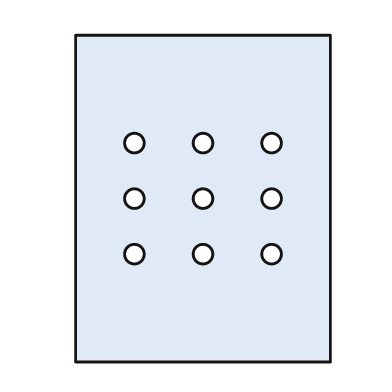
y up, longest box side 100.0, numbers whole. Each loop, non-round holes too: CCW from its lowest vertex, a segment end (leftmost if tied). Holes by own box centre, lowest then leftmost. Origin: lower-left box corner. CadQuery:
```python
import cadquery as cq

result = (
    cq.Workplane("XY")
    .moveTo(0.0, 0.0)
    .lineTo(78.0, 0.0)
    .lineTo(78.0, 100.0)
    .lineTo(0.0, 100.0)
    .close()
    .moveTo(18.0, 33.0)
    .circle(3.0)
    .moveTo(39.0, 33.0)
    .circle(3.0)
    .moveTo(60.0, 33.0)
    .circle(3.0)
    .moveTo(18.0, 50.0)
    .circle(3.0)
    .moveTo(39.0, 50.0)
    .circle(3.0)
    .moveTo(60.0, 50.0)
    .circle(3.0)
    .moveTo(18.0, 67.0)
    .circle(3.0)
    .moveTo(39.0, 67.0)
    .circle(3.0)
    .moveTo(60.0, 67.0)
    .circle(3.0)
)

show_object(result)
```